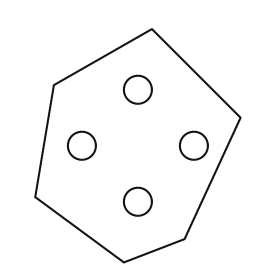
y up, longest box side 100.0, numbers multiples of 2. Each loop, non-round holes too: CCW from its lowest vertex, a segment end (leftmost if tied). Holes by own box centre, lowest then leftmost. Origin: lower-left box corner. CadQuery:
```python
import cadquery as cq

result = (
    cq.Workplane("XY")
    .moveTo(38.0, 0.0)
    .lineTo(64.0, 10.0)
    .lineTo(88.0, 62.0)
    .lineTo(50.0, 100.0)
    .lineTo(8.0, 76.0)
    .lineTo(0.0, 28.0)
    .close()
    .moveTo(44.0, 26.0)
    .circle(6.0)
    .moveTo(20.0, 50.0)
    .circle(6.0)
    .moveTo(68.0, 50.0)
    .circle(6.0)
    .moveTo(44.0, 74.0)
    .circle(6.0)
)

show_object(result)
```